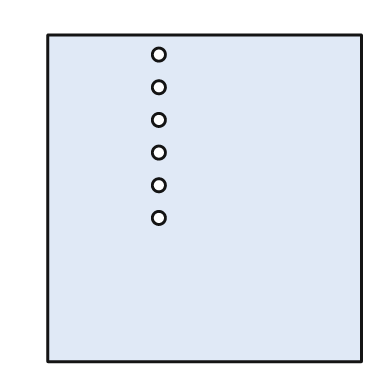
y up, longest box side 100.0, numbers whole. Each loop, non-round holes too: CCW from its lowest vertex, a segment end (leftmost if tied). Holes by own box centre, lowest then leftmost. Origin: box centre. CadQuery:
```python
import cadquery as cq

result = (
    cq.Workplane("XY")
    .moveTo(-48.0, -50.0)
    .lineTo(48.0, -50.0)
    .lineTo(48.0, 50.0)
    .lineTo(-48.0, 50.0)
    .close()
    .moveTo(-14.0, -6.0)
    .circle(2.0)
    .moveTo(-14.0, 4.0)
    .circle(2.0)
    .moveTo(-14.0, 14.0)
    .circle(2.0)
    .moveTo(-14.0, 24.0)
    .circle(2.0)
    .moveTo(-14.0, 34.0)
    .circle(2.0)
    .moveTo(-14.0, 44.0)
    .circle(2.0)
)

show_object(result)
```